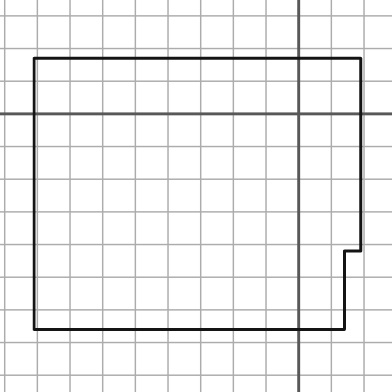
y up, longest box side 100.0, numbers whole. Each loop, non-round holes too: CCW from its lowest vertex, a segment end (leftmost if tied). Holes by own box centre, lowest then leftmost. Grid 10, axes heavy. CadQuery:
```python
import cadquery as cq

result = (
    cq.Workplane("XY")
    .moveTo(-81.0, -66.0)
    .lineTo(14.0, -66.0)
    .lineTo(14.0, -42.0)
    .lineTo(19.0, -42.0)
    .lineTo(19.0, 17.0)
    .lineTo(-81.0, 17.0)
    .close()
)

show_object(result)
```